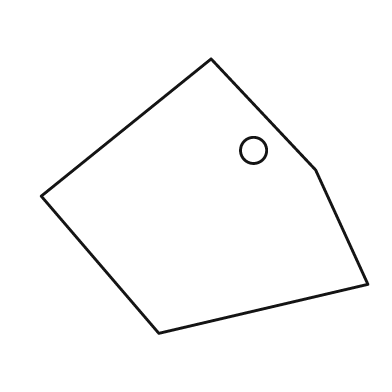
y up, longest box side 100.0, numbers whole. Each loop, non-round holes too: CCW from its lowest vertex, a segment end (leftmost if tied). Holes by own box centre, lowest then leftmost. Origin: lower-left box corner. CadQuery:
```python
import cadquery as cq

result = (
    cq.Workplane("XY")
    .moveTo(36.0, 0.0)
    .lineTo(100.0, 15.0)
    .lineTo(84.0, 50.0)
    .lineTo(52.0, 84.0)
    .lineTo(0.0, 42.0)
    .close()
    .moveTo(65.0, 56.0)
    .circle(4.0)
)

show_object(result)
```